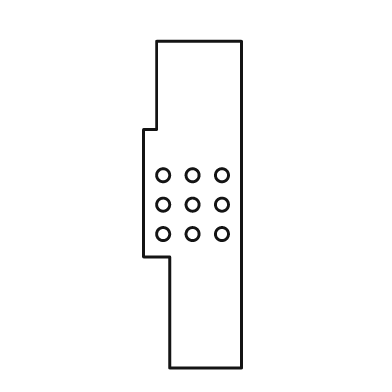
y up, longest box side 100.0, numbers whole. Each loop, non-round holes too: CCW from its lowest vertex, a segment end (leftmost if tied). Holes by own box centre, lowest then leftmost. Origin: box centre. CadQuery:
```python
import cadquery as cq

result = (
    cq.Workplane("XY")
    .moveTo(-7.0, -50.0)
    .lineTo(15.0, -50.0)
    .lineTo(15.0, 50.0)
    .lineTo(-11.0, 50.0)
    .lineTo(-11.0, 23.0)
    .lineTo(-15.0, 23.0)
    .lineTo(-15.0, -16.0)
    .lineTo(-7.0, -16.0)
    .close()
    .moveTo(-9.0, -9.0)
    .circle(2.0)
    .moveTo(0.0, -9.0)
    .circle(2.0)
    .moveTo(9.0, -9.0)
    .circle(2.0)
    .moveTo(-9.0, 0.0)
    .circle(2.0)
    .moveTo(0.0, 0.0)
    .circle(2.0)
    .moveTo(9.0, 0.0)
    .circle(2.0)
    .moveTo(-9.0, 9.0)
    .circle(2.0)
    .moveTo(0.0, 9.0)
    .circle(2.0)
    .moveTo(9.0, 9.0)
    .circle(2.0)
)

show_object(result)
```